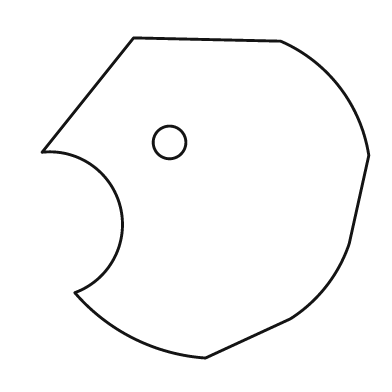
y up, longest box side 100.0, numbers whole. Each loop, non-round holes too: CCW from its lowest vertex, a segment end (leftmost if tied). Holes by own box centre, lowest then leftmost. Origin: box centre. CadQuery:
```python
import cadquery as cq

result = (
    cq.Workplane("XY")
    .moveTo(0.0, -49.0)
    .lineTo(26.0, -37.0)
    .threePointArc((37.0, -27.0), (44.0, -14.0))
    .lineTo(50.0, 13.0)
    .threePointArc((41.0, 34.0), (23.0, 48.0))
    .lineTo(-22.0, 49.0)
    .lineTo(-50.0, 14.0)
    .threePointArc((-26.0, -3.0), (-40.0, -29.0))
    .threePointArc((-22.0, -43.0), (0.0, -49.0))
    .close()
    .moveTo(-11.0, 17.0)
    .circle(5.0)
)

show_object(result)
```